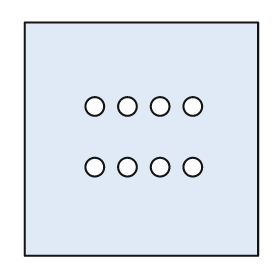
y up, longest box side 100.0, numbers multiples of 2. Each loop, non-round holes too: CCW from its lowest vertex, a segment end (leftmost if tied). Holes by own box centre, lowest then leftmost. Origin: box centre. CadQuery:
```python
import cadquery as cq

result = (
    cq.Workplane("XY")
    .moveTo(-50.0, -50.0)
    .lineTo(50.0, -50.0)
    .lineTo(50.0, 50.0)
    .lineTo(-50.0, 50.0)
    .close()
    .moveTo(-20.0, -12.0)
    .circle(4.0)
    .moveTo(-6.0, -12.0)
    .circle(4.0)
    .moveTo(8.0, -12.0)
    .circle(4.0)
    .moveTo(22.0, -12.0)
    .circle(4.0)
    .moveTo(-20.0, 14.0)
    .circle(4.0)
    .moveTo(-6.0, 14.0)
    .circle(4.0)
    .moveTo(8.0, 14.0)
    .circle(4.0)
    .moveTo(22.0, 14.0)
    .circle(4.0)
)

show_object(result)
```